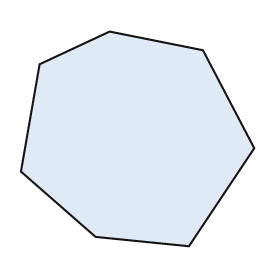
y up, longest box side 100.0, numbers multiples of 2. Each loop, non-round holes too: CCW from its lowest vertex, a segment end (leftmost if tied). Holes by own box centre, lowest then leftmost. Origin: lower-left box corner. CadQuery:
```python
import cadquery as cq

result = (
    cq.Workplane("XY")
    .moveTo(72.0, 0.0)
    .lineTo(100.0, 42.0)
    .lineTo(78.0, 84.0)
    .lineTo(38.0, 92.0)
    .lineTo(8.0, 78.0)
    .lineTo(0.0, 32.0)
    .lineTo(32.0, 4.0)
    .close()
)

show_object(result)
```